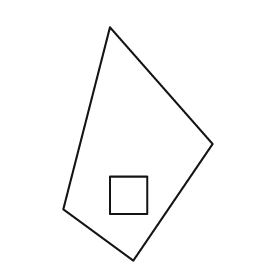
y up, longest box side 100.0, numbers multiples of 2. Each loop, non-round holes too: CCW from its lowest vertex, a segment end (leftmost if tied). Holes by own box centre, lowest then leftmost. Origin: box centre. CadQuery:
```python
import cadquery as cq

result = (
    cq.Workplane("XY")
    .moveTo(-2.0, -50.0)
    .lineTo(32.0, 0.0)
    .lineTo(-12.0, 50.0)
    .lineTo(-32.0, -28.0)
    .close()
    .moveTo(-12.0, -30.0)
    .lineTo(4.0, -30.0)
    .lineTo(4.0, -14.0)
    .lineTo(-12.0, -14.0)
    .close()
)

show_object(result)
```